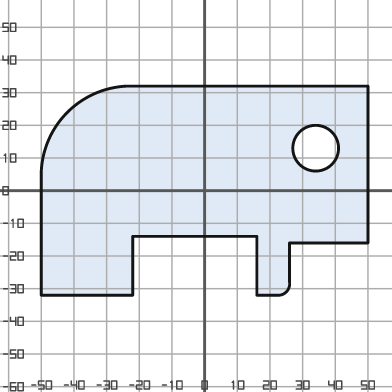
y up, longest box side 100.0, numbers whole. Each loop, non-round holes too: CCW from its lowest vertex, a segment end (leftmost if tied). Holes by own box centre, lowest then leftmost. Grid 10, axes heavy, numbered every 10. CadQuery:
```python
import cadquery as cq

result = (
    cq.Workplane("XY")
    .moveTo(-50.0, -32.0)
    .lineTo(-22.0, -32.0)
    .lineTo(-22.0, -14.0)
    .lineTo(16.0, -14.0)
    .lineTo(16.0, -32.0)
    .lineTo(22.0, -32.0)
    .threePointArc((25.0, -31.0), (26.0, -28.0))
    .lineTo(26.0, -16.0)
    .lineTo(50.0, -16.0)
    .lineTo(50.0, 32.0)
    .lineTo(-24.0, 32.0)
    .threePointArc((-42.0, 24.0), (-50.0, 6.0))
    .close()
    .moveTo(34.0, 13.0)
    .circle(7.0)
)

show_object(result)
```